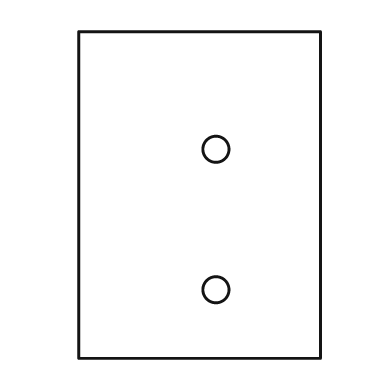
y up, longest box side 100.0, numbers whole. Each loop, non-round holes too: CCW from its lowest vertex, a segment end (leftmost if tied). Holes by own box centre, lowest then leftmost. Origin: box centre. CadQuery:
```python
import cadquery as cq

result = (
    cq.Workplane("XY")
    .moveTo(-37.0, -50.0)
    .lineTo(37.0, -50.0)
    .lineTo(37.0, 50.0)
    .lineTo(-37.0, 50.0)
    .close()
    .moveTo(5.0, -29.0)
    .circle(4.0)
    .moveTo(5.0, 14.0)
    .circle(4.0)
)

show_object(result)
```